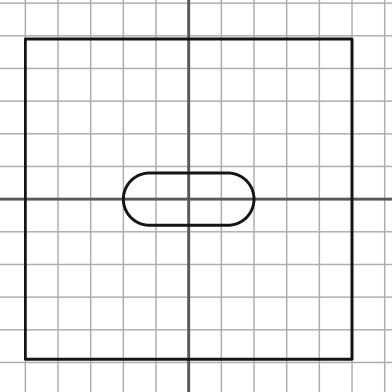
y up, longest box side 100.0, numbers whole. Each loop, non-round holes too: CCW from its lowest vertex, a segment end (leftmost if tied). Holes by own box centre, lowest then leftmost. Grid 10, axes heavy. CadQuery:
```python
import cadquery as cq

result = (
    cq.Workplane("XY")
    .moveTo(-50.0, -49.0)
    .lineTo(50.0, -49.0)
    .lineTo(50.0, 49.0)
    .lineTo(-50.0, 49.0)
    .close()
    .moveTo(-12.0, -8.0)
    .lineTo(12.0, -8.0)
    .threePointArc((20.0, 0.0), (12.0, 8.0))
    .lineTo(-12.0, 8.0)
    .threePointArc((-20.0, 0.0), (-12.0, -8.0))
    .close()
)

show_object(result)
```